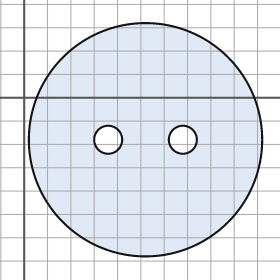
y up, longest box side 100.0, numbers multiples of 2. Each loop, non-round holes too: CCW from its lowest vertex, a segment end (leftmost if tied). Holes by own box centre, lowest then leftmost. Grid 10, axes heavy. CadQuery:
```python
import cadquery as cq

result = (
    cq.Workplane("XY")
    .moveTo(52.0, -18.0)
    .circle(50.0)
    .moveTo(36.0, -18.0)
    .circle(6.0)
    .moveTo(68.0, -18.0)
    .circle(6.0)
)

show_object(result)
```